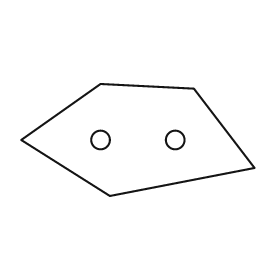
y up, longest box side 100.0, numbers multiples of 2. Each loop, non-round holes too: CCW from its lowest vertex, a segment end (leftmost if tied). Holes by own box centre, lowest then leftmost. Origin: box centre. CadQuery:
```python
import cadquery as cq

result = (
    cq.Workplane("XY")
    .moveTo(-12.0, -24.0)
    .lineTo(50.0, -12.0)
    .lineTo(24.0, 22.0)
    .lineTo(-16.0, 24.0)
    .lineTo(-50.0, 0.0)
    .close()
    .moveTo(-16.0, 0.0)
    .circle(4.0)
    .moveTo(16.0, 0.0)
    .circle(4.0)
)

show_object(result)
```